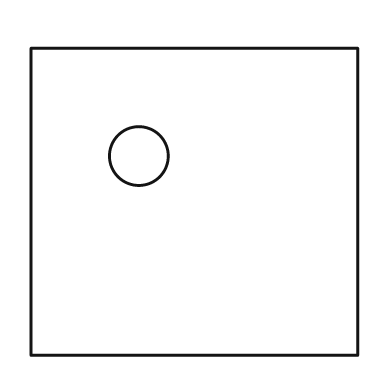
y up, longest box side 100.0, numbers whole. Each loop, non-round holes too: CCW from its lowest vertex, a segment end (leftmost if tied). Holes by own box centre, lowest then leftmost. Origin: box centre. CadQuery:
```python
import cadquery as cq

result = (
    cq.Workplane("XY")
    .moveTo(-50.0, -47.0)
    .lineTo(50.0, -47.0)
    .lineTo(50.0, 47.0)
    .lineTo(-50.0, 47.0)
    .close()
    .moveTo(-17.0, 14.0)
    .circle(9.0)
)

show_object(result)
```